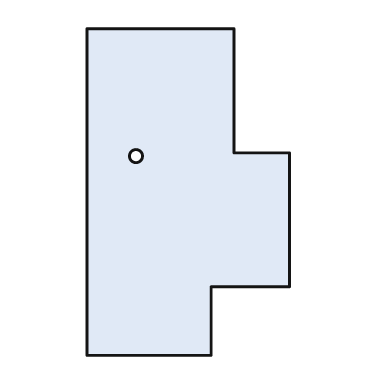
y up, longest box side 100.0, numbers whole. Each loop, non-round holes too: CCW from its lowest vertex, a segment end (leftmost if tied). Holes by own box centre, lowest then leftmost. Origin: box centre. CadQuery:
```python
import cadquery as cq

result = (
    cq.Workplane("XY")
    .moveTo(-31.0, -50.0)
    .lineTo(7.0, -50.0)
    .lineTo(7.0, -29.0)
    .lineTo(31.0, -29.0)
    .lineTo(31.0, 12.0)
    .lineTo(14.0, 12.0)
    .lineTo(14.0, 50.0)
    .lineTo(-31.0, 50.0)
    .close()
    .moveTo(-16.0, 11.0)
    .circle(2.0)
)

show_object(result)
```